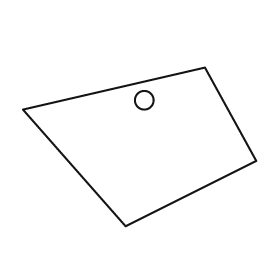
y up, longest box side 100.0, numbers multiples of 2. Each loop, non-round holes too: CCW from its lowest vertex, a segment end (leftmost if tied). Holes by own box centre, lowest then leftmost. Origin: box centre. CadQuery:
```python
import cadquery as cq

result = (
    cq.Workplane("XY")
    .moveTo(-6.0, -34.0)
    .lineTo(50.0, -6.0)
    .lineTo(28.0, 34.0)
    .lineTo(-50.0, 16.0)
    .close()
    .moveTo(2.0, 20.0)
    .circle(4.0)
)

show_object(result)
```